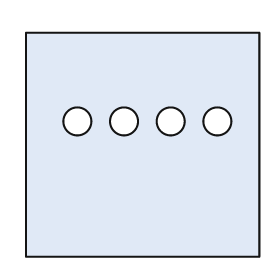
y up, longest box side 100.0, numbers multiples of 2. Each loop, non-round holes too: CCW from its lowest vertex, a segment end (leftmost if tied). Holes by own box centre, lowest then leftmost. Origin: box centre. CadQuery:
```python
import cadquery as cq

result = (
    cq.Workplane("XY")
    .moveTo(-50.0, -48.0)
    .lineTo(50.0, -48.0)
    .lineTo(50.0, 48.0)
    .lineTo(-50.0, 48.0)
    .close()
    .moveTo(-28.0, 10.0)
    .circle(6.0)
    .moveTo(-8.0, 10.0)
    .circle(6.0)
    .moveTo(12.0, 10.0)
    .circle(6.0)
    .moveTo(32.0, 10.0)
    .circle(6.0)
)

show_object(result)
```